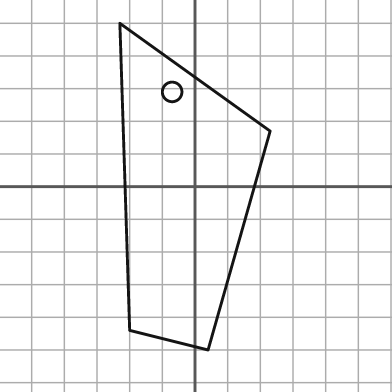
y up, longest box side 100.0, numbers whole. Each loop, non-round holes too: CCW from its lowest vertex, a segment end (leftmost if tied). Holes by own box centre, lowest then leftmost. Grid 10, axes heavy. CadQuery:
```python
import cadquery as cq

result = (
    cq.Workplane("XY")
    .moveTo(4.0, -50.0)
    .lineTo(23.0, 17.0)
    .lineTo(-23.0, 50.0)
    .lineTo(-20.0, -44.0)
    .close()
    .moveTo(-7.0, 29.0)
    .circle(3.0)
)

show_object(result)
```